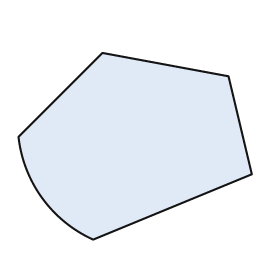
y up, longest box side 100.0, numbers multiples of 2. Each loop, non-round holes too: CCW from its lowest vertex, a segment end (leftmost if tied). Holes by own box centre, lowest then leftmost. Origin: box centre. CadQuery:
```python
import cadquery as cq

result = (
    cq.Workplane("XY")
    .moveTo(-18.0, -40.0)
    .lineTo(50.0, -12.0)
    .lineTo(40.0, 30.0)
    .lineTo(-14.0, 40.0)
    .lineTo(-50.0, 4.0)
    .threePointArc((-40.0, -22.0), (-18.0, -40.0))
    .close()
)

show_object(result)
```